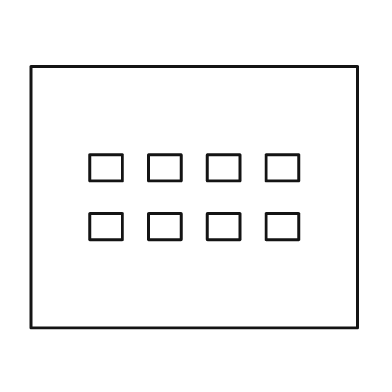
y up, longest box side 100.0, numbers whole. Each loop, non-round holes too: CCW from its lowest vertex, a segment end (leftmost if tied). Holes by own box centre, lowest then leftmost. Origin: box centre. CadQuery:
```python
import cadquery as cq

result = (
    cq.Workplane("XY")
    .moveTo(-50.0, -40.0)
    .lineTo(50.0, -40.0)
    .lineTo(50.0, 40.0)
    .lineTo(-50.0, 40.0)
    .close()
    .moveTo(-32.0, -13.0)
    .lineTo(-22.0, -13.0)
    .lineTo(-22.0, -5.0)
    .lineTo(-32.0, -5.0)
    .close()
    .moveTo(-14.0, -13.0)
    .lineTo(-4.0, -13.0)
    .lineTo(-4.0, -5.0)
    .lineTo(-14.0, -5.0)
    .close()
    .moveTo(4.0, -13.0)
    .lineTo(14.0, -13.0)
    .lineTo(14.0, -5.0)
    .lineTo(4.0, -5.0)
    .close()
    .moveTo(22.0, -13.0)
    .lineTo(32.0, -13.0)
    .lineTo(32.0, -5.0)
    .lineTo(22.0, -5.0)
    .close()
    .moveTo(-32.0, 5.0)
    .lineTo(-22.0, 5.0)
    .lineTo(-22.0, 13.0)
    .lineTo(-32.0, 13.0)
    .close()
    .moveTo(-14.0, 5.0)
    .lineTo(-4.0, 5.0)
    .lineTo(-4.0, 13.0)
    .lineTo(-14.0, 13.0)
    .close()
    .moveTo(4.0, 5.0)
    .lineTo(14.0, 5.0)
    .lineTo(14.0, 13.0)
    .lineTo(4.0, 13.0)
    .close()
    .moveTo(22.0, 5.0)
    .lineTo(32.0, 5.0)
    .lineTo(32.0, 13.0)
    .lineTo(22.0, 13.0)
    .close()
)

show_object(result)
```